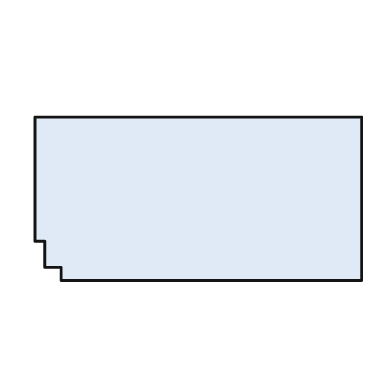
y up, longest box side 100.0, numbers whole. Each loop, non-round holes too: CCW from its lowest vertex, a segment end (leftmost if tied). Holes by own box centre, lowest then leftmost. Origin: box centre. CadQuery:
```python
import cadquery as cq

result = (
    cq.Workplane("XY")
    .moveTo(-42.0, -25.0)
    .lineTo(50.0, -25.0)
    .lineTo(50.0, 25.0)
    .lineTo(-50.0, 25.0)
    .lineTo(-50.0, -13.0)
    .lineTo(-47.0, -13.0)
    .lineTo(-47.0, -21.0)
    .lineTo(-42.0, -21.0)
    .close()
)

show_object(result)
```